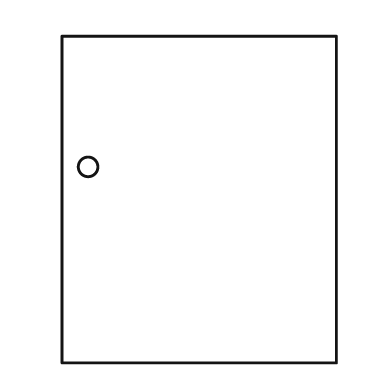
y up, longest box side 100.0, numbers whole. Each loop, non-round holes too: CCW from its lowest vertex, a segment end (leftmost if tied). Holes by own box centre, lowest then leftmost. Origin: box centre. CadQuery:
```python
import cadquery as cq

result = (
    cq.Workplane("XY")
    .moveTo(-42.0, -50.0)
    .lineTo(42.0, -50.0)
    .lineTo(42.0, 50.0)
    .lineTo(-42.0, 50.0)
    .close()
    .moveTo(-34.0, 10.0)
    .circle(3.0)
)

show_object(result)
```